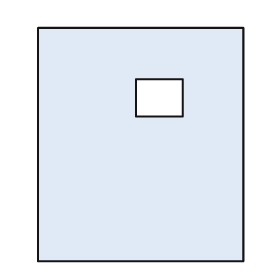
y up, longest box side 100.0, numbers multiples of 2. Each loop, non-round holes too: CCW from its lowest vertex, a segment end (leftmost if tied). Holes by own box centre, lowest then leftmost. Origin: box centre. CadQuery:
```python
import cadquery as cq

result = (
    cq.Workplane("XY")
    .moveTo(-44.0, -50.0)
    .lineTo(44.0, -50.0)
    .lineTo(44.0, 50.0)
    .lineTo(-44.0, 50.0)
    .close()
    .moveTo(-2.0, 12.0)
    .lineTo(18.0, 12.0)
    .lineTo(18.0, 28.0)
    .lineTo(-2.0, 28.0)
    .close()
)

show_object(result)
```